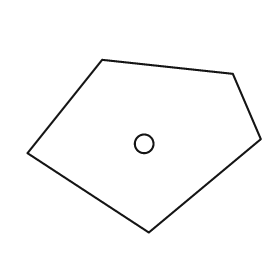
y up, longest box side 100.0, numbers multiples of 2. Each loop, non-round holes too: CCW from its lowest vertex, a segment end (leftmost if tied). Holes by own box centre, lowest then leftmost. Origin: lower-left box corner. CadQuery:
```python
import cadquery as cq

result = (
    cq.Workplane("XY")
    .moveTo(52.0, 0.0)
    .lineTo(100.0, 40.0)
    .lineTo(88.0, 68.0)
    .lineTo(32.0, 74.0)
    .lineTo(0.0, 34.0)
    .close()
    .moveTo(50.0, 38.0)
    .circle(4.0)
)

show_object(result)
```